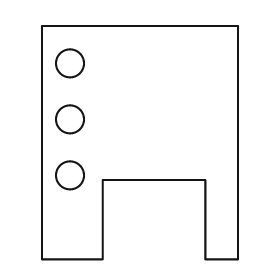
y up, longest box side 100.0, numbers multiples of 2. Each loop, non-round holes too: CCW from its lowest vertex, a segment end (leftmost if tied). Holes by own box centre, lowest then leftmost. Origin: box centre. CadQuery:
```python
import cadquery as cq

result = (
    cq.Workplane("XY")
    .moveTo(-42.0, -50.0)
    .lineTo(-16.0, -50.0)
    .lineTo(-16.0, -16.0)
    .lineTo(28.0, -16.0)
    .lineTo(28.0, -50.0)
    .lineTo(42.0, -50.0)
    .lineTo(42.0, 50.0)
    .lineTo(-42.0, 50.0)
    .close()
    .moveTo(-30.0, -14.0)
    .circle(6.0)
    .moveTo(-30.0, 10.0)
    .circle(6.0)
    .moveTo(-30.0, 34.0)
    .circle(6.0)
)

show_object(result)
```